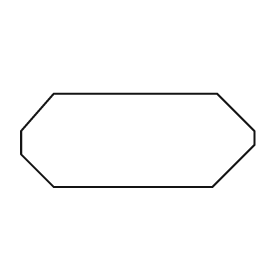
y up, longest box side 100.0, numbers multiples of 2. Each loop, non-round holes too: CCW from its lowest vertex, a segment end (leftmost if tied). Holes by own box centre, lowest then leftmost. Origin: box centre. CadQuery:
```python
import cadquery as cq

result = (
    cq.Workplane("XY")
    .moveTo(-36.0, -20.0)
    .lineTo(32.0, -20.0)
    .lineTo(50.0, -2.0)
    .lineTo(50.0, 4.0)
    .lineTo(34.0, 20.0)
    .lineTo(-36.0, 20.0)
    .lineTo(-50.0, 4.0)
    .lineTo(-50.0, -6.0)
    .close()
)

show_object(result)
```